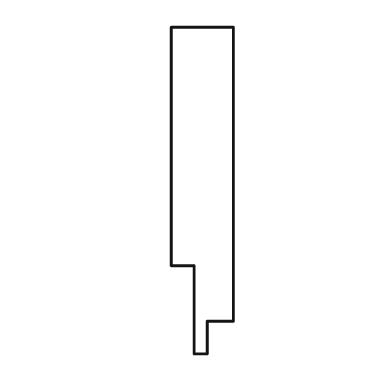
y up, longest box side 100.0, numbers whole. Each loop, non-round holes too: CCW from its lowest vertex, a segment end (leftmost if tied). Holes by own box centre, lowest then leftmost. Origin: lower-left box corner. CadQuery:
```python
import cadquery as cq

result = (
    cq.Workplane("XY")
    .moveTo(7.0, 0.0)
    .lineTo(11.0, 0.0)
    .lineTo(11.0, 10.0)
    .lineTo(19.0, 10.0)
    .lineTo(19.0, 100.0)
    .lineTo(0.0, 100.0)
    .lineTo(0.0, 27.0)
    .lineTo(7.0, 27.0)
    .close()
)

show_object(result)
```